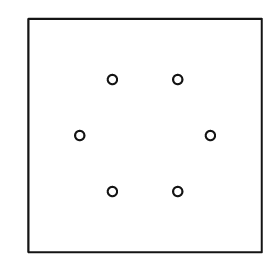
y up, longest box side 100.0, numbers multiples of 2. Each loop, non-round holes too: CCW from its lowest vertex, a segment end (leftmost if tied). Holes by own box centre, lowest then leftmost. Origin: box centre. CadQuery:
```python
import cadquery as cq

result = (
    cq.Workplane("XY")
    .moveTo(-50.0, -50.0)
    .lineTo(50.0, -50.0)
    .lineTo(50.0, 50.0)
    .lineTo(-50.0, 50.0)
    .close()
    .moveTo(-14.0, -24.0)
    .circle(2.0)
    .moveTo(14.0, -24.0)
    .circle(2.0)
    .moveTo(-28.0, 0.0)
    .circle(2.0)
    .moveTo(28.0, 0.0)
    .circle(2.0)
    .moveTo(-14.0, 24.0)
    .circle(2.0)
    .moveTo(14.0, 24.0)
    .circle(2.0)
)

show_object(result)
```